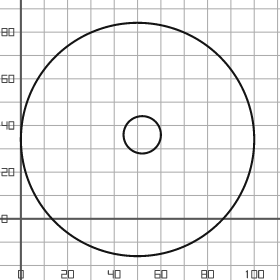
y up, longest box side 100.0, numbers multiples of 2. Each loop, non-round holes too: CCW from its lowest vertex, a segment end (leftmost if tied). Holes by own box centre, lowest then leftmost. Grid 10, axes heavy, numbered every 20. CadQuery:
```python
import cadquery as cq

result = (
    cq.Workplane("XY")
    .moveTo(50.0, 34.0)
    .circle(50.0)
    .moveTo(52.0, 36.0)
    .circle(8.0)
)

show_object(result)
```